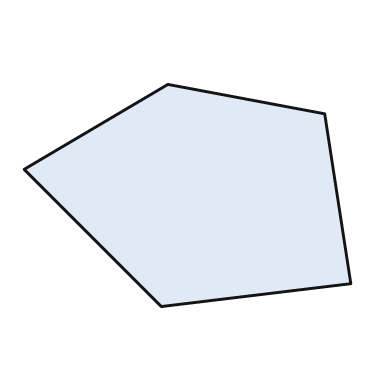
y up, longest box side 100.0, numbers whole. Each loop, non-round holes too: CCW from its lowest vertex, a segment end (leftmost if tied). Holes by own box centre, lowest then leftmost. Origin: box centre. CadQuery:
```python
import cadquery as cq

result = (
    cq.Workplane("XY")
    .moveTo(-8.0, -34.0)
    .lineTo(50.0, -27.0)
    .lineTo(42.0, 25.0)
    .lineTo(-6.0, 34.0)
    .lineTo(-50.0, 8.0)
    .close()
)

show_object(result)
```